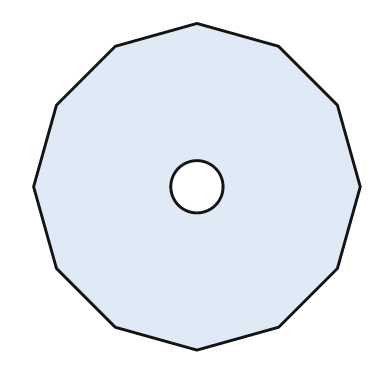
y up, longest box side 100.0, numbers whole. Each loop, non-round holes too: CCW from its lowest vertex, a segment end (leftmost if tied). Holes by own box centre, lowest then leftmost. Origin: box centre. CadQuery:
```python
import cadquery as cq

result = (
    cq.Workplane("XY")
    .moveTo(0.0, -50.0)
    .lineTo(25.0, -43.0)
    .lineTo(43.0, -25.0)
    .lineTo(50.0, 0.0)
    .lineTo(43.0, 25.0)
    .lineTo(25.0, 43.0)
    .lineTo(0.0, 50.0)
    .lineTo(-25.0, 43.0)
    .lineTo(-43.0, 25.0)
    .lineTo(-50.0, 0.0)
    .lineTo(-43.0, -25.0)
    .lineTo(-25.0, -43.0)
    .close()
    .moveTo(0.0, 0.0)
    .circle(8.0)
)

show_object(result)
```